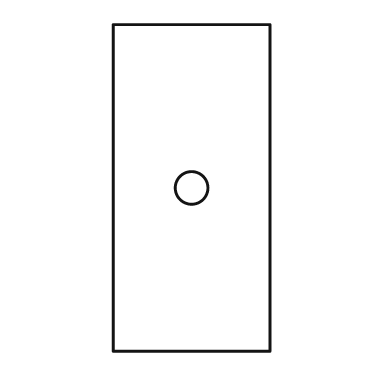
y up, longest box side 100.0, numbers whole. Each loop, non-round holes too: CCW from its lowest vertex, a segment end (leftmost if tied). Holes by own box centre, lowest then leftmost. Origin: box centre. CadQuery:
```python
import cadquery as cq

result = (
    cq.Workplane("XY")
    .moveTo(-24.0, -50.0)
    .lineTo(24.0, -50.0)
    .lineTo(24.0, 50.0)
    .lineTo(-24.0, 50.0)
    .close()
    .moveTo(0.0, 0.0)
    .circle(5.0)
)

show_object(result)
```